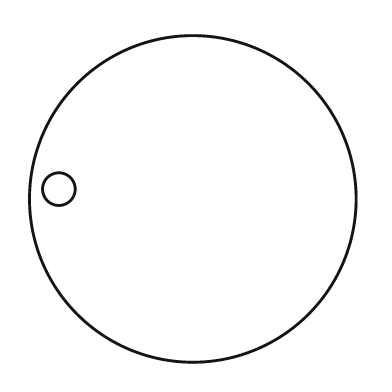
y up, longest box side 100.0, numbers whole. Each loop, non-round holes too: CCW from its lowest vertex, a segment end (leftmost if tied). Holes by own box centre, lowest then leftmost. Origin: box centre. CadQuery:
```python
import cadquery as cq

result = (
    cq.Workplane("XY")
    .moveTo(0.0, 0.0)
    .circle(50.0)
    .moveTo(-41.0, 3.0)
    .circle(5.0)
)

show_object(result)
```